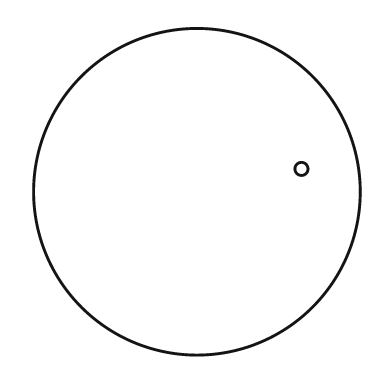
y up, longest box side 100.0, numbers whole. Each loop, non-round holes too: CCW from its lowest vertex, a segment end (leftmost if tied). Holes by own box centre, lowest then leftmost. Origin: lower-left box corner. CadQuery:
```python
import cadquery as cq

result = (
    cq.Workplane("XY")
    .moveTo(50.0, 50.0)
    .circle(50.0)
    .moveTo(82.0, 57.0)
    .circle(2.0)
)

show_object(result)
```